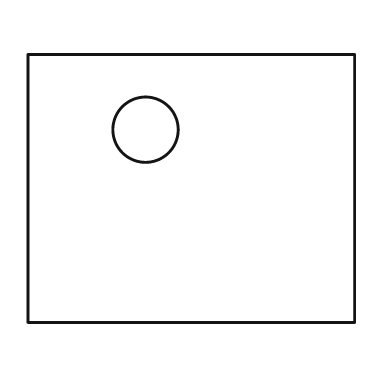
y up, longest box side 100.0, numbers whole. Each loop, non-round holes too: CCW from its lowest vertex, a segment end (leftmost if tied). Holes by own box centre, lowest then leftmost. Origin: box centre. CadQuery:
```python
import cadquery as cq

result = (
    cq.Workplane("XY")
    .moveTo(-50.0, -41.0)
    .lineTo(50.0, -41.0)
    .lineTo(50.0, 41.0)
    .lineTo(-50.0, 41.0)
    .close()
    .moveTo(-14.0, 18.0)
    .circle(10.0)
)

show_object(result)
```